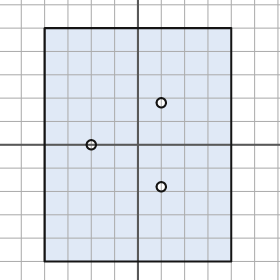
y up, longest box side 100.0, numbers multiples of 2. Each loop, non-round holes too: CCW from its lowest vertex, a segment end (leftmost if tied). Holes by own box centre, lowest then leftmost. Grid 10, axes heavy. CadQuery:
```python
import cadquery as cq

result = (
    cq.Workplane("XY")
    .moveTo(-40.0, -50.0)
    .lineTo(40.0, -50.0)
    .lineTo(40.0, 50.0)
    .lineTo(-40.0, 50.0)
    .close()
    .moveTo(10.0, -18.0)
    .circle(2.0)
    .moveTo(-20.0, 0.0)
    .circle(2.0)
    .moveTo(10.0, 18.0)
    .circle(2.0)
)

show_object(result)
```